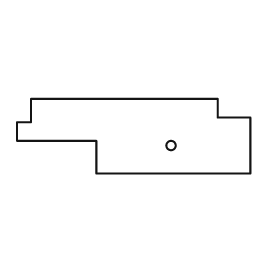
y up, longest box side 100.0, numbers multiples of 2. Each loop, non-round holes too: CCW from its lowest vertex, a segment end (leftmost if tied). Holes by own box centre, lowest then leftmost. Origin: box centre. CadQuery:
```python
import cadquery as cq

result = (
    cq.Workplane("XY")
    .moveTo(-16.0, -16.0)
    .lineTo(50.0, -16.0)
    .lineTo(50.0, 8.0)
    .lineTo(36.0, 8.0)
    .lineTo(36.0, 16.0)
    .lineTo(-44.0, 16.0)
    .lineTo(-44.0, 6.0)
    .lineTo(-50.0, 6.0)
    .lineTo(-50.0, -2.0)
    .lineTo(-16.0, -2.0)
    .close()
    .moveTo(16.0, -4.0)
    .circle(2.0)
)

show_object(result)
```